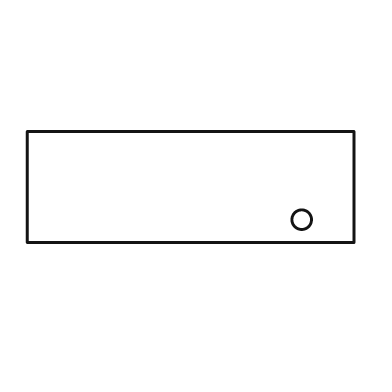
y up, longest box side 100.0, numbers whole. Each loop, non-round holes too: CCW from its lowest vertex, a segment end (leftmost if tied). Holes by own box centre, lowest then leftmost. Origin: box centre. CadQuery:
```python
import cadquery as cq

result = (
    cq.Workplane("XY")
    .moveTo(-50.0, -17.0)
    .lineTo(50.0, -17.0)
    .lineTo(50.0, 17.0)
    .lineTo(-50.0, 17.0)
    .close()
    .moveTo(34.0, -10.0)
    .circle(3.0)
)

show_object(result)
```